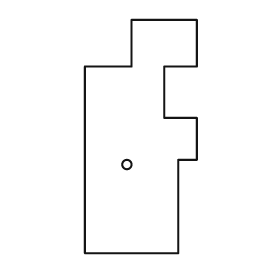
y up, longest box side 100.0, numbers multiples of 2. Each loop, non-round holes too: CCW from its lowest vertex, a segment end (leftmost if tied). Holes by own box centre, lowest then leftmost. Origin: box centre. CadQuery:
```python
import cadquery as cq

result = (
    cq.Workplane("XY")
    .moveTo(-24.0, -50.0)
    .lineTo(16.0, -50.0)
    .lineTo(16.0, -10.0)
    .lineTo(24.0, -10.0)
    .lineTo(24.0, 8.0)
    .lineTo(10.0, 8.0)
    .lineTo(10.0, 30.0)
    .lineTo(24.0, 30.0)
    .lineTo(24.0, 50.0)
    .lineTo(-4.0, 50.0)
    .lineTo(-4.0, 30.0)
    .lineTo(-24.0, 30.0)
    .close()
    .moveTo(-6.0, -12.0)
    .circle(2.0)
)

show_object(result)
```